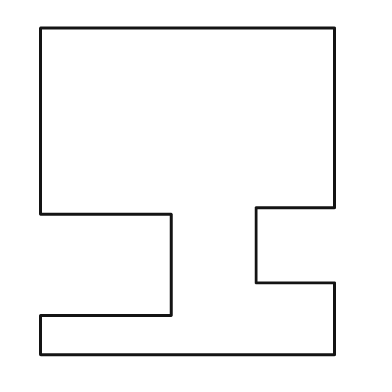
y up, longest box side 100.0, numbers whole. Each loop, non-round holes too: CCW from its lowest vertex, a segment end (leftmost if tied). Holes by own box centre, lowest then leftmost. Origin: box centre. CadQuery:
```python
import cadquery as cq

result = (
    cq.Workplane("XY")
    .moveTo(-45.0, -50.0)
    .lineTo(45.0, -50.0)
    .lineTo(45.0, -28.0)
    .lineTo(21.0, -28.0)
    .lineTo(21.0, -5.0)
    .lineTo(45.0, -5.0)
    .lineTo(45.0, 50.0)
    .lineTo(-45.0, 50.0)
    .lineTo(-45.0, -7.0)
    .lineTo(-5.0, -7.0)
    .lineTo(-5.0, -38.0)
    .lineTo(-45.0, -38.0)
    .close()
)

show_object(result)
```